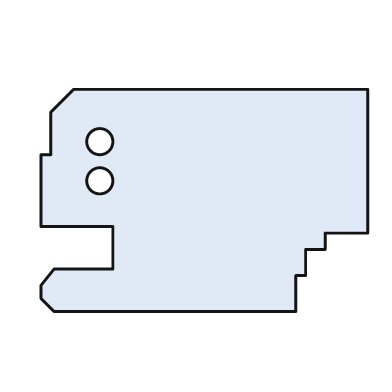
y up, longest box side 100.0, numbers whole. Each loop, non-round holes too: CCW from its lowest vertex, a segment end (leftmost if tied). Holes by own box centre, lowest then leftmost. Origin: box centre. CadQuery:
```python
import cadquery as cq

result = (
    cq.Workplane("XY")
    .moveTo(-46.0, -34.0)
    .lineTo(28.0, -34.0)
    .lineTo(28.0, -23.0)
    .lineTo(31.0, -23.0)
    .lineTo(31.0, -15.0)
    .lineTo(37.0, -15.0)
    .lineTo(37.0, -10.0)
    .lineTo(50.0, -10.0)
    .lineTo(50.0, 34.0)
    .lineTo(-40.0, 34.0)
    .lineTo(-47.0, 27.0)
    .lineTo(-47.0, 14.0)
    .lineTo(-50.0, 14.0)
    .lineTo(-50.0, -8.0)
    .lineTo(-28.0, -8.0)
    .lineTo(-28.0, -21.0)
    .lineTo(-46.0, -21.0)
    .lineTo(-50.0, -26.0)
    .lineTo(-50.0, -30.0)
    .close()
    .moveTo(-32.0, 6.0)
    .circle(4.0)
    .moveTo(-32.0, 18.0)
    .circle(4.0)
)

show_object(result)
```